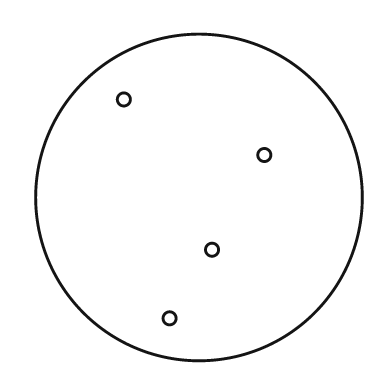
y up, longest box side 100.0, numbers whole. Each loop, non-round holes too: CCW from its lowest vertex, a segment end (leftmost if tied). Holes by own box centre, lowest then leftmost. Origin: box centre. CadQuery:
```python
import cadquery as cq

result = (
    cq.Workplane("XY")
    .moveTo(0.0, 0.0)
    .circle(50.0)
    .moveTo(-9.0, -37.0)
    .circle(2.0)
    .moveTo(4.0, -16.0)
    .circle(2.0)
    .moveTo(20.0, 13.0)
    .circle(2.0)
    .moveTo(-23.0, 30.0)
    .circle(2.0)
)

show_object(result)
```